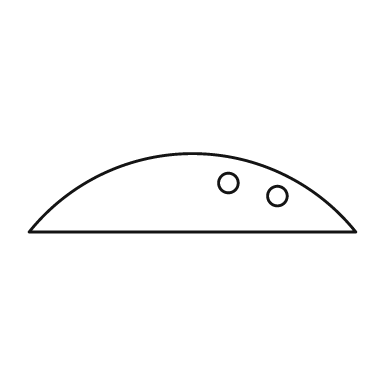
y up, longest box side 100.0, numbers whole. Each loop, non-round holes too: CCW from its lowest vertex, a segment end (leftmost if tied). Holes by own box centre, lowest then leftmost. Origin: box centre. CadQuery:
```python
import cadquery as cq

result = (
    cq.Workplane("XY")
    .moveTo(-50.0, -12.0)
    .lineTo(50.0, -12.0)
    .threePointArc((0.0, 12.0), (-50.0, -12.0))
    .close()
    .moveTo(26.0, -1.0)
    .circle(3.0)
    .moveTo(11.0, 3.0)
    .circle(3.0)
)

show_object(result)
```